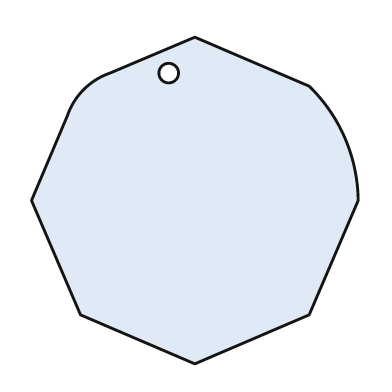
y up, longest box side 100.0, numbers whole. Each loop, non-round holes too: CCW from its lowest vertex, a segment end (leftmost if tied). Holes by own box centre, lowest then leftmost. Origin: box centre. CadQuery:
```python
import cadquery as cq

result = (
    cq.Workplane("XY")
    .moveTo(0.0, -50.0)
    .lineTo(35.0, -35.0)
    .lineTo(50.0, 0.0)
    .threePointArc((46.0, 19.0), (35.0, 35.0))
    .lineTo(0.0, 50.0)
    .lineTo(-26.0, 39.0)
    .threePointArc((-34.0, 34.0), (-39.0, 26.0))
    .lineTo(-50.0, 0.0)
    .lineTo(-35.0, -35.0)
    .close()
    .moveTo(-8.0, 39.0)
    .circle(3.0)
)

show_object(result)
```